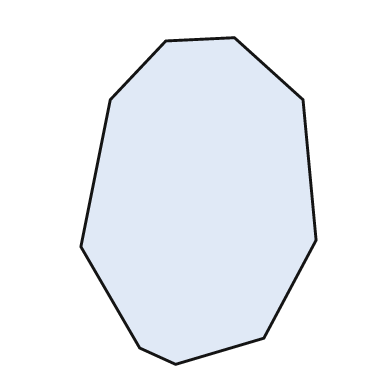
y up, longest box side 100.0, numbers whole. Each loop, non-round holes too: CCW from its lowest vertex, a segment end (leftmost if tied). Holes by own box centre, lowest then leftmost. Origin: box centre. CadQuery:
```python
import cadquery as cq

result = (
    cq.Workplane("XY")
    .moveTo(-7.0, -50.0)
    .lineTo(20.0, -42.0)
    .lineTo(36.0, -12.0)
    .lineTo(32.0, 31.0)
    .lineTo(11.0, 50.0)
    .lineTo(-10.0, 49.0)
    .lineTo(-27.0, 31.0)
    .lineTo(-36.0, -14.0)
    .lineTo(-18.0, -45.0)
    .close()
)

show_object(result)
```